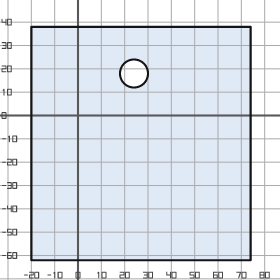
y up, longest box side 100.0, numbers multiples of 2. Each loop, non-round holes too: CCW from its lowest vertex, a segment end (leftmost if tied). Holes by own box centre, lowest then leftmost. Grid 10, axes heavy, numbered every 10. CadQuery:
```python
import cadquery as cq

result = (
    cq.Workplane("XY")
    .moveTo(-20.0, -62.0)
    .lineTo(74.0, -62.0)
    .lineTo(74.0, 38.0)
    .lineTo(-20.0, 38.0)
    .close()
    .moveTo(24.0, 18.0)
    .circle(6.0)
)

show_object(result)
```